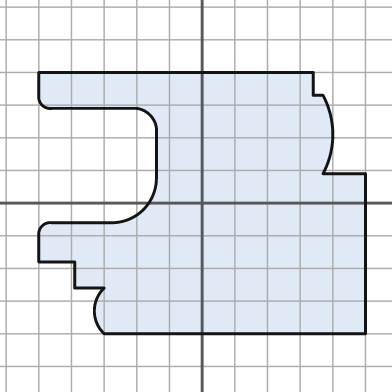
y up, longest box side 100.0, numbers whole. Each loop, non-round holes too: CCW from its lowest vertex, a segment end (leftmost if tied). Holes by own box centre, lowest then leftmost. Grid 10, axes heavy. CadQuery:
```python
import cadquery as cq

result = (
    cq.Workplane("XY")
    .moveTo(-30.0, -40.0)
    .lineTo(50.0, -40.0)
    .lineTo(50.0, 9.0)
    .lineTo(37.0, 9.0)
    .threePointArc((40.0, 21.0), (37.0, 33.0))
    .lineTo(34.0, 33.0)
    .lineTo(34.0, 40.0)
    .lineTo(-50.0, 40.0)
    .lineTo(-50.0, 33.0)
    .threePointArc((-49.0, 30.0), (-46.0, 29.0))
    .lineTo(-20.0, 29.0)
    .threePointArc((-16.0, 27.0), (-14.0, 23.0))
    .lineTo(-14.0, 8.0)
    .threePointArc((-18.0, -2.0), (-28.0, -6.0))
    .lineTo(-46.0, -6.0)
    .threePointArc((-49.0, -7.0), (-50.0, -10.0))
    .lineTo(-50.0, -18.0)
    .lineTo(-39.0, -18.0)
    .lineTo(-39.0, -26.0)
    .lineTo(-30.0, -26.0)
    .threePointArc((-33.0, -33.0), (-30.0, -40.0))
    .close()
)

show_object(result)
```